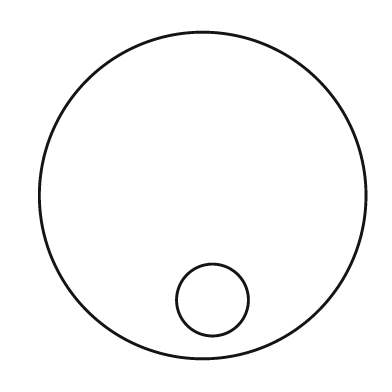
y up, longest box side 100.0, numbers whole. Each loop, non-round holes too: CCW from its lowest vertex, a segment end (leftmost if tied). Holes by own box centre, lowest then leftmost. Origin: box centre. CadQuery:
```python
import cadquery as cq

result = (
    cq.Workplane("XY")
    .moveTo(0.0, 0.0)
    .circle(50.0)
    .moveTo(3.0, -32.0)
    .circle(11.0)
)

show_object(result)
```